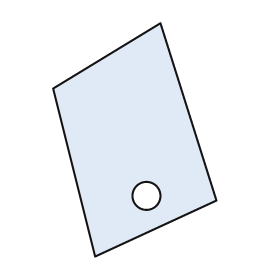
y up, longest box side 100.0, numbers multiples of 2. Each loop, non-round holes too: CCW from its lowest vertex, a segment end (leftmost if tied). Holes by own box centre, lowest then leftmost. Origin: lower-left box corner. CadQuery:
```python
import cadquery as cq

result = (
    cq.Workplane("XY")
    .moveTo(18.0, 0.0)
    .lineTo(70.0, 24.0)
    .lineTo(46.0, 100.0)
    .lineTo(0.0, 72.0)
    .close()
    .moveTo(40.0, 26.0)
    .circle(6.0)
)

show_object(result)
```